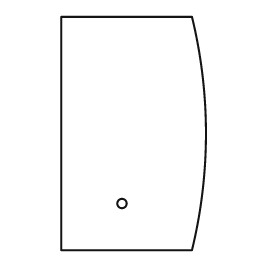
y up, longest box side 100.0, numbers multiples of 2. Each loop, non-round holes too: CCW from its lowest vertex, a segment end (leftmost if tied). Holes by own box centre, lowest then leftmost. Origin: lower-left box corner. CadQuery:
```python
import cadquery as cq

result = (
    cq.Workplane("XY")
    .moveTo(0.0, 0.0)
    .lineTo(56.0, 0.0)
    .threePointArc((62.0, 50.0), (56.0, 100.0))
    .lineTo(0.0, 100.0)
    .close()
    .moveTo(26.0, 20.0)
    .circle(2.0)
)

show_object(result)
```